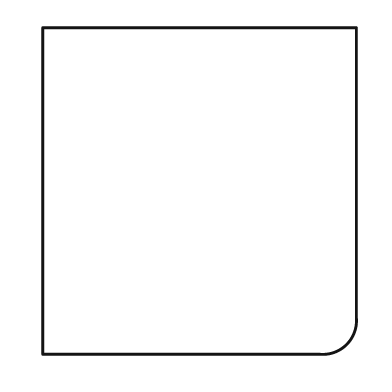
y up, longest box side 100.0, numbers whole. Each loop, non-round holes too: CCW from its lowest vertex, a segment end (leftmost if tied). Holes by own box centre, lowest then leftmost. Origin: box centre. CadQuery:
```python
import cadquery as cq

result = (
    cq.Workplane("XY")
    .moveTo(-48.0, -50.0)
    .lineTo(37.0, -50.0)
    .threePointArc((45.0, -47.0), (48.0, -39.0))
    .lineTo(48.0, 50.0)
    .lineTo(-48.0, 50.0)
    .close()
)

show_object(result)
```